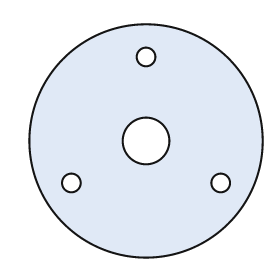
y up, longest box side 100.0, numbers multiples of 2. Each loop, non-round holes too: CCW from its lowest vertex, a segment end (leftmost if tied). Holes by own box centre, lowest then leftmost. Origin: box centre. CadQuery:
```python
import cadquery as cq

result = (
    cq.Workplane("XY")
    .moveTo(0.0, 0.0)
    .circle(50.0)
    .moveTo(-32.0, -18.0)
    .circle(4.0)
    .moveTo(32.0, -18.0)
    .circle(4.0)
    .moveTo(0.0, 0.0)
    .circle(10.0)
    .moveTo(0.0, 36.0)
    .circle(4.0)
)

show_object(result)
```